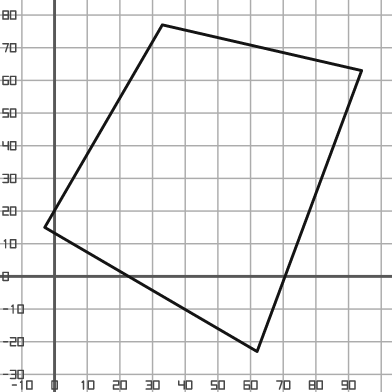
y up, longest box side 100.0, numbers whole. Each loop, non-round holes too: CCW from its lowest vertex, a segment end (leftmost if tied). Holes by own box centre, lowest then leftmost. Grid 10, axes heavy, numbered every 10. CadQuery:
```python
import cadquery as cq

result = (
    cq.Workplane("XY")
    .moveTo(62.0, -23.0)
    .lineTo(94.0, 63.0)
    .lineTo(33.0, 77.0)
    .lineTo(-3.0, 15.0)
    .close()
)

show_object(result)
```